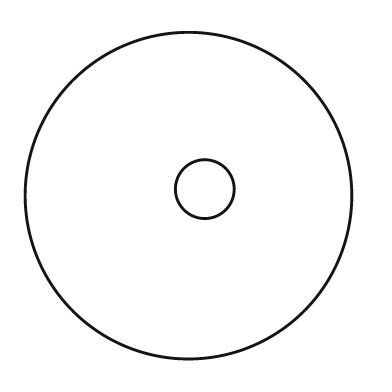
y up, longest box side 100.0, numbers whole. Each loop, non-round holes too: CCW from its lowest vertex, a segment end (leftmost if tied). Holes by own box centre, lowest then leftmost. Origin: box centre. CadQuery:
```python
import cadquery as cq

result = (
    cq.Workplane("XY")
    .moveTo(0.0, 0.0)
    .circle(50.0)
    .moveTo(5.0, 2.0)
    .circle(9.0)
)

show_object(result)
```